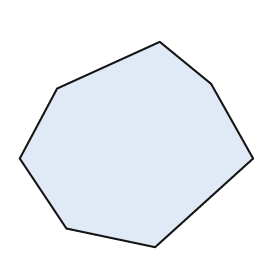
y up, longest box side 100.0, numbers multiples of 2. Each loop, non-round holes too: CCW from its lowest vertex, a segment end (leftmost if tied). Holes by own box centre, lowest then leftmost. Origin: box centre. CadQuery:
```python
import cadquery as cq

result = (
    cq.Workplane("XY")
    .moveTo(8.0, -44.0)
    .lineTo(50.0, -6.0)
    .lineTo(32.0, 26.0)
    .lineTo(10.0, 44.0)
    .lineTo(-34.0, 24.0)
    .lineTo(-50.0, -6.0)
    .lineTo(-30.0, -36.0)
    .close()
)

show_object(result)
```